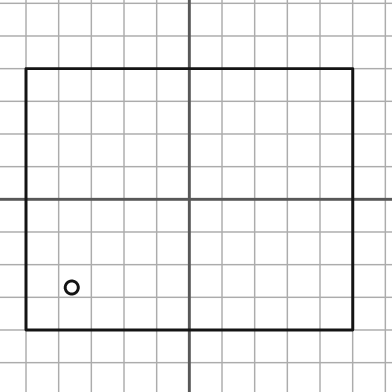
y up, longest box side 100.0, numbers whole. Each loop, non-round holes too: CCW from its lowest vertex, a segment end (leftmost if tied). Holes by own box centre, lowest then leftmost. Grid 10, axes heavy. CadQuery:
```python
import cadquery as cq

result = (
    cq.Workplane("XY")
    .moveTo(-50.0, -40.0)
    .lineTo(50.0, -40.0)
    .lineTo(50.0, 40.0)
    .lineTo(-50.0, 40.0)
    .close()
    .moveTo(-36.0, -27.0)
    .circle(2.0)
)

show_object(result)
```